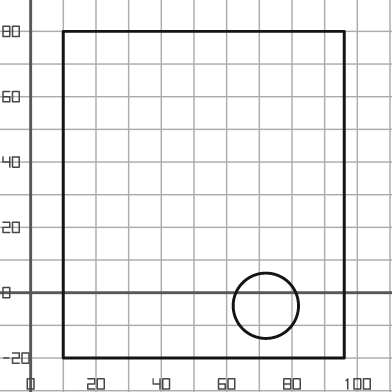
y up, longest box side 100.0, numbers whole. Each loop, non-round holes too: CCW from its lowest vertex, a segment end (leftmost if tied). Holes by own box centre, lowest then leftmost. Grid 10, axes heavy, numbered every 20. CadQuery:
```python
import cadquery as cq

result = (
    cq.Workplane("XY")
    .moveTo(10.0, -20.0)
    .lineTo(96.0, -20.0)
    .lineTo(96.0, 80.0)
    .lineTo(10.0, 80.0)
    .close()
    .moveTo(72.0, -4.0)
    .circle(10.0)
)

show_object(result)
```